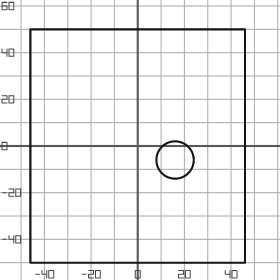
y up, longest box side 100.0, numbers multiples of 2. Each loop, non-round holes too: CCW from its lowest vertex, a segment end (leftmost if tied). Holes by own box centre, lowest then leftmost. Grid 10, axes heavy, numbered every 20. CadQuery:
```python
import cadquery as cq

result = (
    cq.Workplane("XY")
    .moveTo(-46.0, -50.0)
    .lineTo(46.0, -50.0)
    .lineTo(46.0, 50.0)
    .lineTo(-46.0, 50.0)
    .close()
    .moveTo(16.0, -6.0)
    .circle(8.0)
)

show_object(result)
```